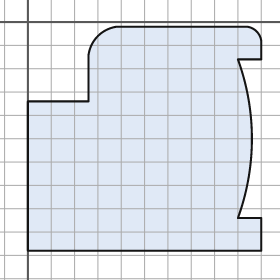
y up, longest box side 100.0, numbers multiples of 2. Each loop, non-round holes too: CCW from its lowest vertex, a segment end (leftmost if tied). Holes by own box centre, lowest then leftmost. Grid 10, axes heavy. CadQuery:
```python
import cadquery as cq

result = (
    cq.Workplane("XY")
    .moveTo(0.0, -98.0)
    .lineTo(100.0, -98.0)
    .lineTo(100.0, -84.0)
    .lineTo(90.0, -84.0)
    .threePointArc((96.0, -50.0), (90.0, -16.0))
    .lineTo(100.0, -16.0)
    .lineTo(100.0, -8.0)
    .threePointArc((98.0, -4.0), (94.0, -2.0))
    .lineTo(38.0, -2.0)
    .threePointArc((30.0, -6.0), (26.0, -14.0))
    .lineTo(26.0, -34.0)
    .lineTo(0.0, -34.0)
    .close()
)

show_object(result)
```